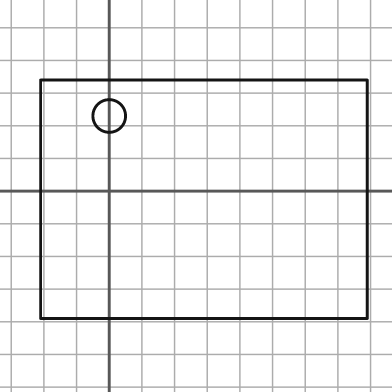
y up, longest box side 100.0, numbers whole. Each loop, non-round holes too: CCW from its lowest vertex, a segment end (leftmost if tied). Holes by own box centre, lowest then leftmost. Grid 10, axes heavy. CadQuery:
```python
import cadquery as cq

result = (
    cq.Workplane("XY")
    .moveTo(-21.0, -39.0)
    .lineTo(79.0, -39.0)
    .lineTo(79.0, 34.0)
    .lineTo(-21.0, 34.0)
    .close()
    .moveTo(0.0, 23.0)
    .circle(5.0)
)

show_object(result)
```